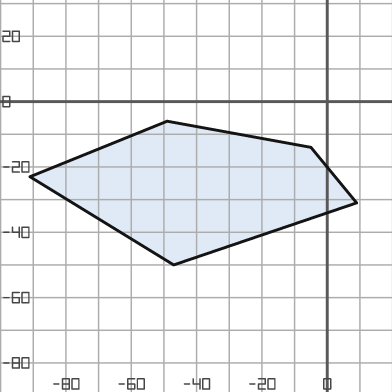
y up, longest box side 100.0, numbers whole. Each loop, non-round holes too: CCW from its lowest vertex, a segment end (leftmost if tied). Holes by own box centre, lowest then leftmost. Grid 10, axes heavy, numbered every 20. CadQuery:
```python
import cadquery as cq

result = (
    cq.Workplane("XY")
    .moveTo(-47.0, -50.0)
    .lineTo(9.0, -31.0)
    .lineTo(-5.0, -14.0)
    .lineTo(-49.0, -6.0)
    .lineTo(-91.0, -23.0)
    .close()
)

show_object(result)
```